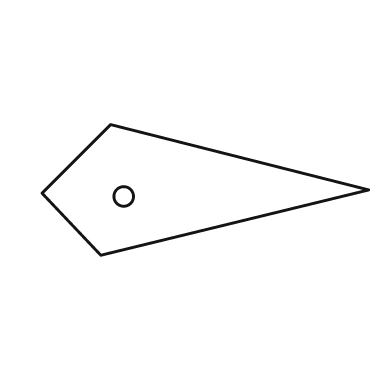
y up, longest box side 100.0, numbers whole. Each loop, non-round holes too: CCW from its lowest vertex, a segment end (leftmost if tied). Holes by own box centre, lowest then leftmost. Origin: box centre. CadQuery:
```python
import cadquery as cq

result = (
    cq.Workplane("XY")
    .moveTo(-32.0, -20.0)
    .lineTo(50.0, 0.0)
    .lineTo(-29.0, 20.0)
    .lineTo(-50.0, -1.0)
    .close()
    .moveTo(-25.0, -2.0)
    .circle(3.0)
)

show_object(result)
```